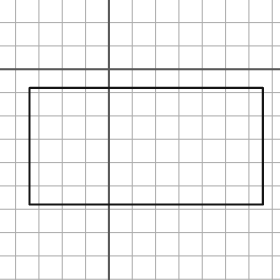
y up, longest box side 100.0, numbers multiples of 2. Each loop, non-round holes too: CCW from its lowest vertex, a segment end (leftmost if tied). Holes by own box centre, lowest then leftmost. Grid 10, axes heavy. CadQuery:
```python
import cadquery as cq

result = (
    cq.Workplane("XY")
    .moveTo(-34.0, -58.0)
    .lineTo(66.0, -58.0)
    .lineTo(66.0, -8.0)
    .lineTo(-34.0, -8.0)
    .close()
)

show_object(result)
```